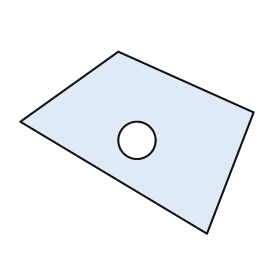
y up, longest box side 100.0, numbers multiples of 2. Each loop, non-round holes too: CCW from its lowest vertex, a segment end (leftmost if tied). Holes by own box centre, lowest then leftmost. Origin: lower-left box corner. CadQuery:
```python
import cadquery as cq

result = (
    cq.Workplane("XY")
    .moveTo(80.0, 0.0)
    .lineTo(100.0, 52.0)
    .lineTo(42.0, 78.0)
    .lineTo(0.0, 48.0)
    .close()
    .moveTo(50.0, 40.0)
    .circle(8.0)
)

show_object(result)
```